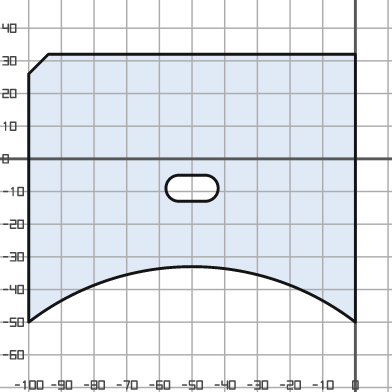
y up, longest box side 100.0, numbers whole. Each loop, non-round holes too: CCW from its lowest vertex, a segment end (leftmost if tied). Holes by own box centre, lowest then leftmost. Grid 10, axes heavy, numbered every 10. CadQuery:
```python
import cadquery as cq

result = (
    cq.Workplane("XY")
    .moveTo(-100.0, -50.0)
    .threePointArc((-50.0, -33.0), (0.0, -50.0))
    .lineTo(0.0, 32.0)
    .lineTo(-94.0, 32.0)
    .lineTo(-100.0, 26.0)
    .close()
    .moveTo(-54.0, -13.0)
    .lineTo(-46.0, -13.0)
    .threePointArc((-42.0, -9.0), (-46.0, -5.0))
    .lineTo(-54.0, -5.0)
    .threePointArc((-58.0, -9.0), (-54.0, -13.0))
    .close()
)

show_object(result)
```